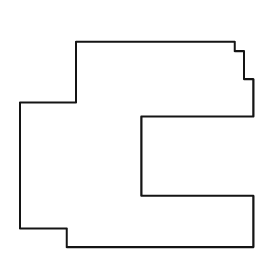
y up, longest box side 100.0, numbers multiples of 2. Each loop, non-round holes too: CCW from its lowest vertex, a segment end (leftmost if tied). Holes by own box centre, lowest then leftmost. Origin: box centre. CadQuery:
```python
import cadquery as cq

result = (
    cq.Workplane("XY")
    .moveTo(-30.0, -44.0)
    .lineTo(50.0, -44.0)
    .lineTo(50.0, -22.0)
    .lineTo(2.0, -22.0)
    .lineTo(2.0, 12.0)
    .lineTo(50.0, 12.0)
    .lineTo(50.0, 28.0)
    .lineTo(46.0, 28.0)
    .lineTo(46.0, 40.0)
    .lineTo(42.0, 40.0)
    .lineTo(42.0, 44.0)
    .lineTo(-26.0, 44.0)
    .lineTo(-26.0, 18.0)
    .lineTo(-50.0, 18.0)
    .lineTo(-50.0, -36.0)
    .lineTo(-30.0, -36.0)
    .close()
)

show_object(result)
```